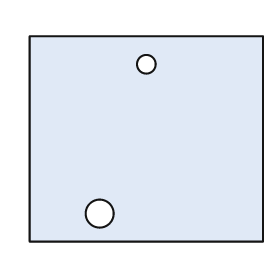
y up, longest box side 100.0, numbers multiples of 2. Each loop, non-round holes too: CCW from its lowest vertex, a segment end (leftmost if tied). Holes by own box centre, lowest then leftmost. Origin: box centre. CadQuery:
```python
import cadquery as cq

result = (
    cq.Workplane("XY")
    .moveTo(-50.0, -44.0)
    .lineTo(50.0, -44.0)
    .lineTo(50.0, 44.0)
    .lineTo(-50.0, 44.0)
    .close()
    .moveTo(-20.0, -32.0)
    .circle(6.0)
    .moveTo(0.0, 32.0)
    .circle(4.0)
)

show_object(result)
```